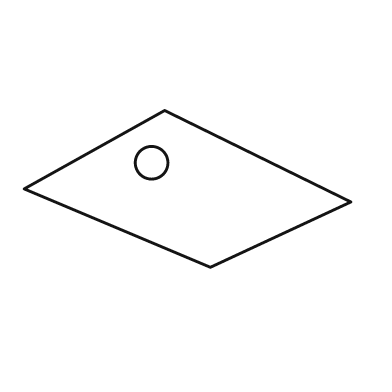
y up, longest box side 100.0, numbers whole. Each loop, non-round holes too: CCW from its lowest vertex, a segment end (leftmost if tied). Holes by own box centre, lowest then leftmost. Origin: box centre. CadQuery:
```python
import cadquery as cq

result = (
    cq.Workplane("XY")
    .moveTo(7.0, -24.0)
    .lineTo(50.0, -4.0)
    .lineTo(-7.0, 24.0)
    .lineTo(-50.0, 0.0)
    .close()
    .moveTo(-11.0, 8.0)
    .circle(5.0)
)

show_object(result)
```